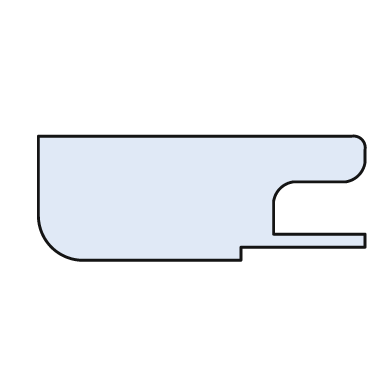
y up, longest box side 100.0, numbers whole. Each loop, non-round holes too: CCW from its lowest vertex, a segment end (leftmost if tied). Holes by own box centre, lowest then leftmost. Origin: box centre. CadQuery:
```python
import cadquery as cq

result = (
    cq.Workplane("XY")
    .moveTo(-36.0, -19.0)
    .lineTo(12.0, -19.0)
    .lineTo(12.0, -15.0)
    .lineTo(50.0, -15.0)
    .lineTo(50.0, -11.0)
    .lineTo(22.0, -11.0)
    .lineTo(22.0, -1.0)
    .threePointArc((24.0, 3.0), (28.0, 5.0))
    .lineTo(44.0, 5.0)
    .threePointArc((48.0, 7.0), (50.0, 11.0))
    .lineTo(50.0, 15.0)
    .threePointArc((49.0, 18.0), (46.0, 19.0))
    .lineTo(-50.0, 19.0)
    .lineTo(-50.0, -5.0)
    .threePointArc((-46.0, -15.0), (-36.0, -19.0))
    .close()
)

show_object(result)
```